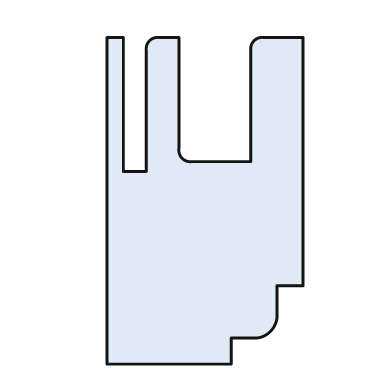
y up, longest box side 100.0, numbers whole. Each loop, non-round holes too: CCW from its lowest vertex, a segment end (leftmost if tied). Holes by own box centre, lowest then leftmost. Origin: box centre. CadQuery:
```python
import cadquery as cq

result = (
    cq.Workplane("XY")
    .moveTo(-30.0, -50.0)
    .lineTo(8.0, -50.0)
    .lineTo(8.0, -42.0)
    .lineTo(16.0, -42.0)
    .threePointArc((20.0, -40.0), (22.0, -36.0))
    .lineTo(22.0, -26.0)
    .lineTo(30.0, -26.0)
    .lineTo(30.0, 50.0)
    .lineTo(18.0, 50.0)
    .threePointArc((15.0, 49.0), (14.0, 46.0))
    .lineTo(14.0, 12.0)
    .lineTo(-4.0, 12.0)
    .threePointArc((-7.0, 13.0), (-8.0, 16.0))
    .lineTo(-8.0, 50.0)
    .lineTo(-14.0, 50.0)
    .threePointArc((-17.0, 49.0), (-18.0, 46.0))
    .lineTo(-18.0, 9.0)
    .lineTo(-25.0, 9.0)
    .lineTo(-25.0, 50.0)
    .lineTo(-30.0, 50.0)
    .close()
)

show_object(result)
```